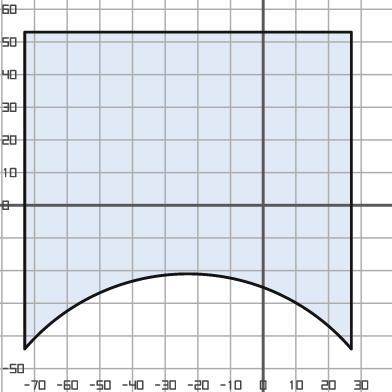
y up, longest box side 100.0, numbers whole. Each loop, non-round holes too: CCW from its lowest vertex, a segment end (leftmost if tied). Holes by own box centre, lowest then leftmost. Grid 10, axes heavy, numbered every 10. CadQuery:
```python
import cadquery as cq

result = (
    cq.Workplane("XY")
    .moveTo(-73.0, -44.0)
    .threePointArc((-23.0, -21.0), (27.0, -44.0))
    .lineTo(27.0, 53.0)
    .lineTo(-73.0, 53.0)
    .close()
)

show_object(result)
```